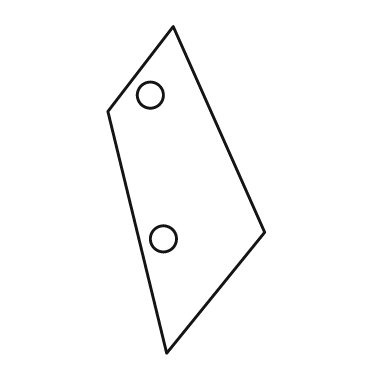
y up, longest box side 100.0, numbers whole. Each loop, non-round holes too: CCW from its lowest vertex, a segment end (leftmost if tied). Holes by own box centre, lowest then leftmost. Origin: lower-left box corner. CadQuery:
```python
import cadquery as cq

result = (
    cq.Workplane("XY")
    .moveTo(18.0, 0.0)
    .lineTo(48.0, 37.0)
    .lineTo(20.0, 100.0)
    .lineTo(0.0, 74.0)
    .close()
    .moveTo(17.0, 35.0)
    .circle(4.0)
    .moveTo(13.0, 79.0)
    .circle(4.0)
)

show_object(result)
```